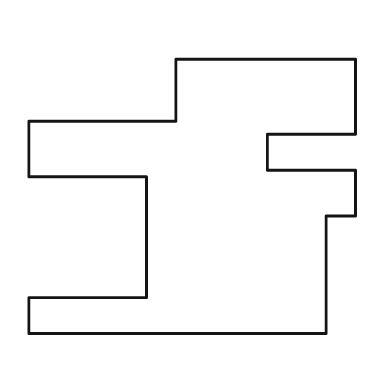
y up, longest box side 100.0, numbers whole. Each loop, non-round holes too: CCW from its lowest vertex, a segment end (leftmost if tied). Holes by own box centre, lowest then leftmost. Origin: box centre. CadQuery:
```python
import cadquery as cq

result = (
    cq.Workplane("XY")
    .moveTo(-50.0, -42.0)
    .lineTo(41.0, -42.0)
    .lineTo(41.0, -6.0)
    .lineTo(50.0, -6.0)
    .lineTo(50.0, 8.0)
    .lineTo(23.0, 8.0)
    .lineTo(23.0, 19.0)
    .lineTo(50.0, 19.0)
    .lineTo(50.0, 42.0)
    .lineTo(-5.0, 42.0)
    .lineTo(-5.0, 23.0)
    .lineTo(-50.0, 23.0)
    .lineTo(-50.0, 6.0)
    .lineTo(-14.0, 6.0)
    .lineTo(-14.0, -31.0)
    .lineTo(-50.0, -31.0)
    .close()
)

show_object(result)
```